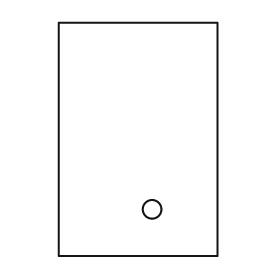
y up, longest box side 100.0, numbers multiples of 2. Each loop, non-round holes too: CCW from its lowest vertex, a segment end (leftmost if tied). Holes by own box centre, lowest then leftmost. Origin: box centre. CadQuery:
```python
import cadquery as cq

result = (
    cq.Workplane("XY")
    .moveTo(-34.0, -50.0)
    .lineTo(34.0, -50.0)
    .lineTo(34.0, 50.0)
    .lineTo(-34.0, 50.0)
    .close()
    .moveTo(6.0, -30.0)
    .circle(4.0)
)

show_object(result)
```